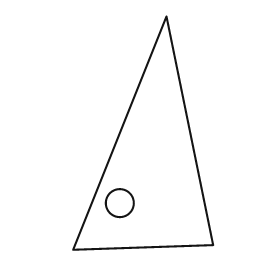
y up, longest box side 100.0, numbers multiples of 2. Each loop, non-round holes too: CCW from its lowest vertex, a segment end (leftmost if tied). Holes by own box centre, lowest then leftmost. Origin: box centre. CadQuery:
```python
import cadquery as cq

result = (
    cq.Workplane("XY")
    .moveTo(-30.0, -50.0)
    .lineTo(30.0, -48.0)
    .lineTo(10.0, 50.0)
    .close()
    .moveTo(-10.0, -30.0)
    .circle(6.0)
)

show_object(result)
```